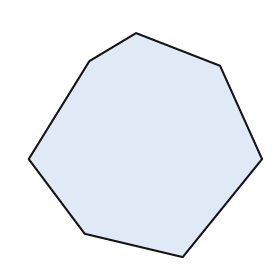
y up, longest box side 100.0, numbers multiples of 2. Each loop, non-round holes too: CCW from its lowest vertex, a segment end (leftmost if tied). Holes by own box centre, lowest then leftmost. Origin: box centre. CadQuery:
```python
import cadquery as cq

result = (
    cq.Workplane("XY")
    .moveTo(16.0, -48.0)
    .lineTo(50.0, -6.0)
    .lineTo(32.0, 34.0)
    .lineTo(-4.0, 48.0)
    .lineTo(-24.0, 36.0)
    .lineTo(-50.0, -6.0)
    .lineTo(-26.0, -38.0)
    .close()
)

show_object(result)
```